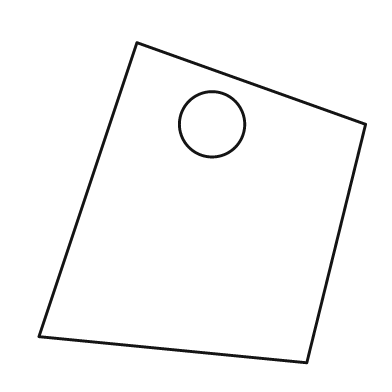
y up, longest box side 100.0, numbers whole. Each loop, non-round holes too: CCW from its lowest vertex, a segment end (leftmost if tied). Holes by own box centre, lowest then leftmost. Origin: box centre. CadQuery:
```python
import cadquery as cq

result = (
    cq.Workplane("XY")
    .moveTo(32.0, -49.0)
    .lineTo(50.0, 24.0)
    .lineTo(-20.0, 49.0)
    .lineTo(-50.0, -41.0)
    .close()
    .moveTo(3.0, 24.0)
    .circle(10.0)
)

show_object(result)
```